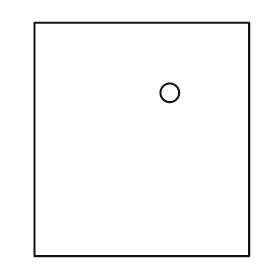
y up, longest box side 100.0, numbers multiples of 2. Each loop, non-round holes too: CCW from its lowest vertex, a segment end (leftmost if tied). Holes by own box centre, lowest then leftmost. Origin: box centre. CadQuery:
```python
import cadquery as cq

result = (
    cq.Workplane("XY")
    .moveTo(-46.0, -50.0)
    .lineTo(46.0, -50.0)
    .lineTo(46.0, 50.0)
    .lineTo(-46.0, 50.0)
    .close()
    .moveTo(12.0, 20.0)
    .circle(4.0)
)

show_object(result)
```